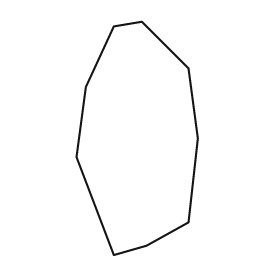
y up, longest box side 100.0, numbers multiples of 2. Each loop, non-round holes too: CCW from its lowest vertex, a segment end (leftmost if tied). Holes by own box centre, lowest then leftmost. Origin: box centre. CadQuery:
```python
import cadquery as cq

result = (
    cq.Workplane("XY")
    .moveTo(-10.0, -50.0)
    .lineTo(4.0, -46.0)
    .lineTo(22.0, -36.0)
    .lineTo(26.0, 0.0)
    .lineTo(22.0, 30.0)
    .lineTo(2.0, 50.0)
    .lineTo(-10.0, 48.0)
    .lineTo(-22.0, 22.0)
    .lineTo(-26.0, -8.0)
    .close()
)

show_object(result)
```